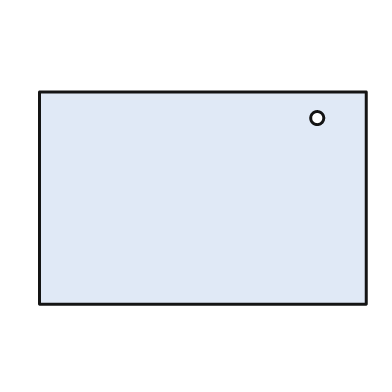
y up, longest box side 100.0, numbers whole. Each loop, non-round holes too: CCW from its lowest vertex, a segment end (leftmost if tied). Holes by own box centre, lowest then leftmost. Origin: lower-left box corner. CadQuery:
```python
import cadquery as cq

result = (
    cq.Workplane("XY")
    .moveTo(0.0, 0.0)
    .lineTo(100.0, 0.0)
    .lineTo(100.0, 65.0)
    .lineTo(0.0, 65.0)
    .close()
    .moveTo(85.0, 57.0)
    .circle(2.0)
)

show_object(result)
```